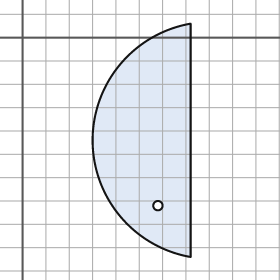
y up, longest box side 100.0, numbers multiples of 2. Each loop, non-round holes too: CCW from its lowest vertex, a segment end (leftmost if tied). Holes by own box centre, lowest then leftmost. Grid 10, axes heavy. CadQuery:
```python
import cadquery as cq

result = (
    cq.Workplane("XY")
    .moveTo(72.0, -94.0)
    .lineTo(72.0, 6.0)
    .threePointArc((30.0, -44.0), (72.0, -94.0))
    .close()
    .moveTo(58.0, -72.0)
    .circle(2.0)
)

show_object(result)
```